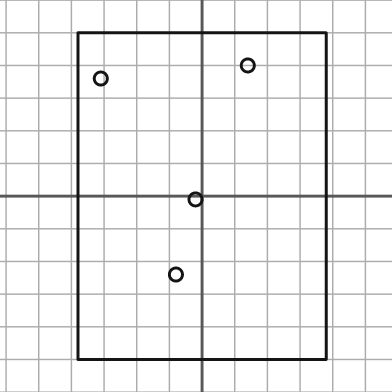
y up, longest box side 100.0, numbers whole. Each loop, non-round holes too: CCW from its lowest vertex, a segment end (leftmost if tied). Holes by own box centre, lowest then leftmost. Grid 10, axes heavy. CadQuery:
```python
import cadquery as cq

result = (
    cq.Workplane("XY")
    .moveTo(-38.0, -50.0)
    .lineTo(38.0, -50.0)
    .lineTo(38.0, 50.0)
    .lineTo(-38.0, 50.0)
    .close()
    .moveTo(-8.0, -24.0)
    .circle(2.0)
    .moveTo(-2.0, -1.0)
    .circle(2.0)
    .moveTo(-31.0, 36.0)
    .circle(2.0)
    .moveTo(14.0, 40.0)
    .circle(2.0)
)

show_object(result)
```